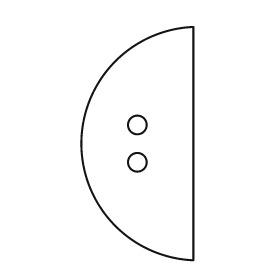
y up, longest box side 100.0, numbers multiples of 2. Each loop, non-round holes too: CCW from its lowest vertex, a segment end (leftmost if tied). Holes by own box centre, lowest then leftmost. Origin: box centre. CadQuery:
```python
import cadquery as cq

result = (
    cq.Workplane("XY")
    .moveTo(24.0, -50.0)
    .lineTo(24.0, 50.0)
    .threePointArc((-24.0, 0.0), (24.0, -50.0))
    .close()
    .moveTo(0.0, -8.0)
    .circle(4.0)
    .moveTo(0.0, 8.0)
    .circle(4.0)
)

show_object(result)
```